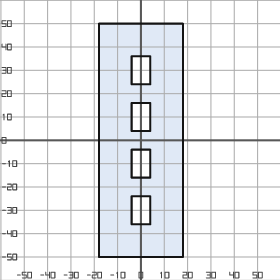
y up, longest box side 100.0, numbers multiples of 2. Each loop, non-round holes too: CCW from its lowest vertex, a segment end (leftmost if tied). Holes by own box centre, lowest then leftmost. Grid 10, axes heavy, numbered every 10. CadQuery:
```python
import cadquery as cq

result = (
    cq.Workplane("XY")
    .moveTo(-18.0, -50.0)
    .lineTo(18.0, -50.0)
    .lineTo(18.0, 50.0)
    .lineTo(-18.0, 50.0)
    .close()
    .moveTo(-4.0, -36.0)
    .lineTo(4.0, -36.0)
    .lineTo(4.0, -24.0)
    .lineTo(-4.0, -24.0)
    .close()
    .moveTo(-4.0, -16.0)
    .lineTo(4.0, -16.0)
    .lineTo(4.0, -4.0)
    .lineTo(-4.0, -4.0)
    .close()
    .moveTo(-4.0, 4.0)
    .lineTo(4.0, 4.0)
    .lineTo(4.0, 16.0)
    .lineTo(-4.0, 16.0)
    .close()
    .moveTo(-4.0, 24.0)
    .lineTo(4.0, 24.0)
    .lineTo(4.0, 36.0)
    .lineTo(-4.0, 36.0)
    .close()
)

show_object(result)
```